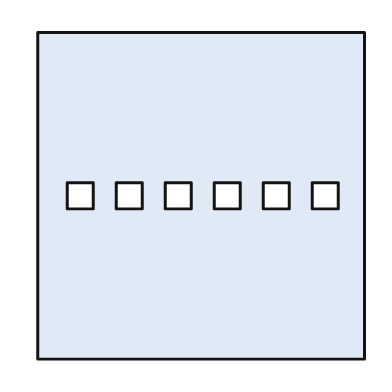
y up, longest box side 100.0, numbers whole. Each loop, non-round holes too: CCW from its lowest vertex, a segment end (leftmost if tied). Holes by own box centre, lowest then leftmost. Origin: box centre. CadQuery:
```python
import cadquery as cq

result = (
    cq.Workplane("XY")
    .moveTo(-50.0, -50.0)
    .lineTo(50.0, -50.0)
    .lineTo(50.0, 50.0)
    .lineTo(-50.0, 50.0)
    .close()
    .moveTo(-41.0, -4.0)
    .lineTo(-33.0, -4.0)
    .lineTo(-33.0, 4.0)
    .lineTo(-41.0, 4.0)
    .close()
    .moveTo(-26.0, -4.0)
    .lineTo(-18.0, -4.0)
    .lineTo(-18.0, 4.0)
    .lineTo(-26.0, 4.0)
    .close()
    .moveTo(-11.0, -4.0)
    .lineTo(-3.0, -4.0)
    .lineTo(-3.0, 4.0)
    .lineTo(-11.0, 4.0)
    .close()
    .moveTo(4.0, -4.0)
    .lineTo(12.0, -4.0)
    .lineTo(12.0, 4.0)
    .lineTo(4.0, 4.0)
    .close()
    .moveTo(19.0, -4.0)
    .lineTo(27.0, -4.0)
    .lineTo(27.0, 4.0)
    .lineTo(19.0, 4.0)
    .close()
    .moveTo(34.0, -4.0)
    .lineTo(42.0, -4.0)
    .lineTo(42.0, 4.0)
    .lineTo(34.0, 4.0)
    .close()
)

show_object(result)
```